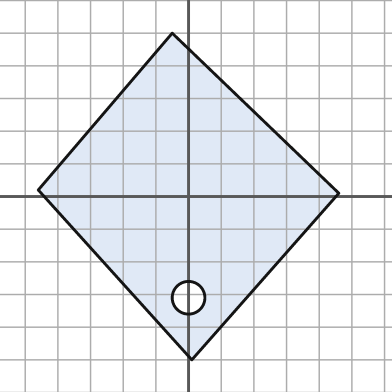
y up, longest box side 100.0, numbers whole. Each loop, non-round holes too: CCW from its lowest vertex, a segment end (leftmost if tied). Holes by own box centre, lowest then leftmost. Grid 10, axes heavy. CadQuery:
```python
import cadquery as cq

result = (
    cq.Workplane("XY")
    .moveTo(1.0, -50.0)
    .lineTo(46.0, 1.0)
    .lineTo(-5.0, 50.0)
    .lineTo(-46.0, 2.0)
    .close()
    .moveTo(0.0, -31.0)
    .circle(5.0)
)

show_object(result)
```